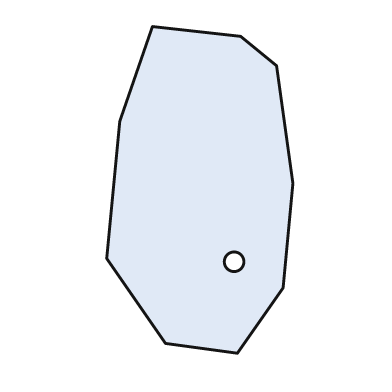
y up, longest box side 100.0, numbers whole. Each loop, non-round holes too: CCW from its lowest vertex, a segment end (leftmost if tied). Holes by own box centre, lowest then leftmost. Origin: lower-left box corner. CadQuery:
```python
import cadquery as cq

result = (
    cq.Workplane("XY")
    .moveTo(40.0, 0.0)
    .lineTo(54.0, 20.0)
    .lineTo(57.0, 52.0)
    .lineTo(52.0, 88.0)
    .lineTo(41.0, 97.0)
    .lineTo(14.0, 100.0)
    .lineTo(4.0, 71.0)
    .lineTo(0.0, 29.0)
    .lineTo(18.0, 3.0)
    .close()
    .moveTo(39.0, 28.0)
    .circle(3.0)
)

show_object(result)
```